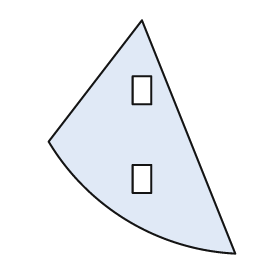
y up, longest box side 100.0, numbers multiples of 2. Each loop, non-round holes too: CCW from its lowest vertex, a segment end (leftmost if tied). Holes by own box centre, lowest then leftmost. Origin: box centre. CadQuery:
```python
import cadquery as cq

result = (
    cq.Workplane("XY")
    .moveTo(40.0, -50.0)
    .lineTo(0.0, 50.0)
    .lineTo(-40.0, -2.0)
    .threePointArc((-6.0, -36.0), (40.0, -50.0))
    .close()
    .moveTo(-4.0, -24.0)
    .lineTo(4.0, -24.0)
    .lineTo(4.0, -12.0)
    .lineTo(-4.0, -12.0)
    .close()
    .moveTo(-4.0, 14.0)
    .lineTo(4.0, 14.0)
    .lineTo(4.0, 26.0)
    .lineTo(-4.0, 26.0)
    .close()
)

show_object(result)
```